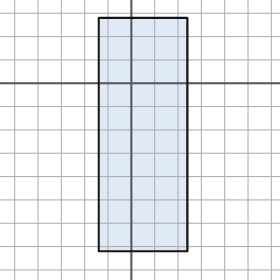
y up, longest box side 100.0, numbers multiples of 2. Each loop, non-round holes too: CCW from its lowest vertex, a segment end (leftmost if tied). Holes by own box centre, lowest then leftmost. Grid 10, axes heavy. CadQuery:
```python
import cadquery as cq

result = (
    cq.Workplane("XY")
    .moveTo(-14.0, -72.0)
    .lineTo(24.0, -72.0)
    .lineTo(24.0, 28.0)
    .lineTo(-14.0, 28.0)
    .close()
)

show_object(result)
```